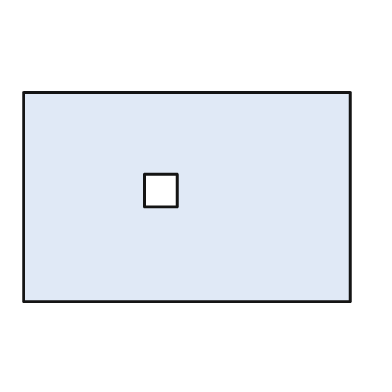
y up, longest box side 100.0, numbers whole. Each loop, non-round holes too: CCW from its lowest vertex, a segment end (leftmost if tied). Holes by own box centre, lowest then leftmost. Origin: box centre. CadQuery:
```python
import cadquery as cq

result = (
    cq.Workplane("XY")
    .moveTo(-50.0, -32.0)
    .lineTo(50.0, -32.0)
    .lineTo(50.0, 32.0)
    .lineTo(-50.0, 32.0)
    .close()
    .moveTo(-13.0, -3.0)
    .lineTo(-3.0, -3.0)
    .lineTo(-3.0, 7.0)
    .lineTo(-13.0, 7.0)
    .close()
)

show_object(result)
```